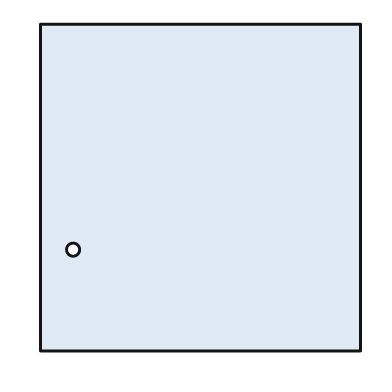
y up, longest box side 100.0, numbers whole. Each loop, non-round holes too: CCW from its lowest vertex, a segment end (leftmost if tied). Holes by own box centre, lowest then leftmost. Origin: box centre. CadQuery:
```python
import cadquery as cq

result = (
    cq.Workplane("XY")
    .moveTo(-49.0, -50.0)
    .lineTo(49.0, -50.0)
    .lineTo(49.0, 50.0)
    .lineTo(-49.0, 50.0)
    .close()
    .moveTo(-39.0, -19.0)
    .circle(2.0)
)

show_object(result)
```